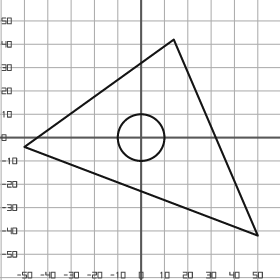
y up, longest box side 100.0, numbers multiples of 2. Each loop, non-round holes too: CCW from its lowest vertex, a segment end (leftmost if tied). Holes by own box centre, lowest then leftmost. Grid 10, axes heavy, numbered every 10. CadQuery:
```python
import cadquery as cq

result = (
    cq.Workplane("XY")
    .moveTo(50.0, -42.0)
    .lineTo(14.0, 42.0)
    .lineTo(-50.0, -4.0)
    .close()
    .moveTo(0.0, 0.0)
    .circle(10.0)
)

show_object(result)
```